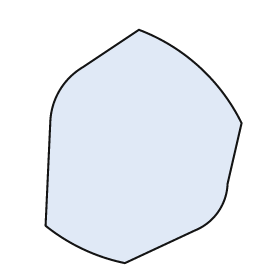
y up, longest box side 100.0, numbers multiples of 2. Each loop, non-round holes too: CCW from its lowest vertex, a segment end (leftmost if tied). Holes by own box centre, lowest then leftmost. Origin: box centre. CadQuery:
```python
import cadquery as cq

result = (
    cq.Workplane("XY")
    .moveTo(-8.0, -50.0)
    .lineTo(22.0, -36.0)
    .threePointArc((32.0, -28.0), (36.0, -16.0))
    .lineTo(42.0, 10.0)
    .threePointArc((24.0, 34.0), (-2.0, 50.0))
    .lineTo(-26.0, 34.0)
    .threePointArc((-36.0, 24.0), (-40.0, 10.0))
    .lineTo(-42.0, -34.0)
    .threePointArc((-26.0, -44.0), (-8.0, -50.0))
    .close()
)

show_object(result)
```